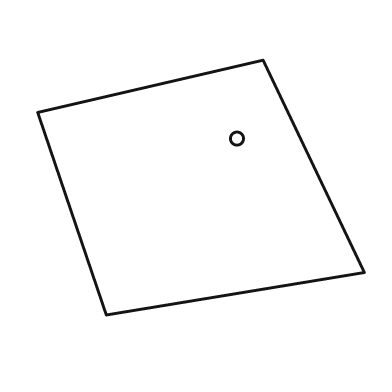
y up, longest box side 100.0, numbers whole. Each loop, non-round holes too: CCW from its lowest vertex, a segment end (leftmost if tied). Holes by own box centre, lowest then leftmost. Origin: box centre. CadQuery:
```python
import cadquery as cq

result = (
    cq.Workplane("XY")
    .moveTo(-29.0, -39.0)
    .lineTo(50.0, -26.0)
    .lineTo(19.0, 39.0)
    .lineTo(-50.0, 23.0)
    .close()
    .moveTo(11.0, 15.0)
    .circle(2.0)
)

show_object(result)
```